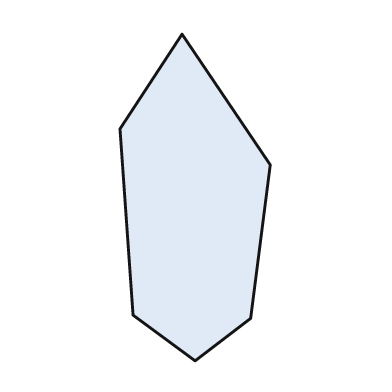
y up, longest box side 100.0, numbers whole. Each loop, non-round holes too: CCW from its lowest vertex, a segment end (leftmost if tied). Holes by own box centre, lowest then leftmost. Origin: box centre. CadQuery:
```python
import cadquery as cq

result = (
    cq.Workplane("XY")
    .moveTo(0.0, -50.0)
    .lineTo(17.0, -37.0)
    .lineTo(23.0, 10.0)
    .lineTo(-4.0, 50.0)
    .lineTo(-23.0, 21.0)
    .lineTo(-19.0, -36.0)
    .close()
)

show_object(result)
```